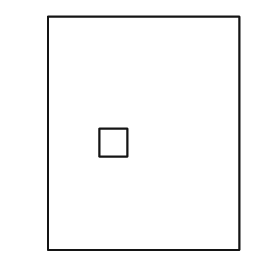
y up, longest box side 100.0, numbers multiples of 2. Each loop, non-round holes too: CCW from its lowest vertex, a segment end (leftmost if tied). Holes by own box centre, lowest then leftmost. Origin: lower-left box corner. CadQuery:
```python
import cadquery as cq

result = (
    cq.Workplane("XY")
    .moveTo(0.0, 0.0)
    .lineTo(82.0, 0.0)
    .lineTo(82.0, 100.0)
    .lineTo(0.0, 100.0)
    .close()
    .moveTo(22.0, 40.0)
    .lineTo(34.0, 40.0)
    .lineTo(34.0, 52.0)
    .lineTo(22.0, 52.0)
    .close()
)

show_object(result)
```